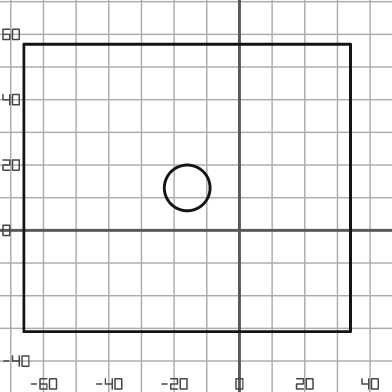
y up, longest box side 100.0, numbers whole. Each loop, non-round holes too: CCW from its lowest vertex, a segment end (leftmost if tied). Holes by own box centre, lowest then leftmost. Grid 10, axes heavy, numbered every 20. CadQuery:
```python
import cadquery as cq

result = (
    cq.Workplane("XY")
    .moveTo(-66.0, -31.0)
    .lineTo(34.0, -31.0)
    .lineTo(34.0, 57.0)
    .lineTo(-66.0, 57.0)
    .close()
    .moveTo(-16.0, 13.0)
    .circle(7.0)
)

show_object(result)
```